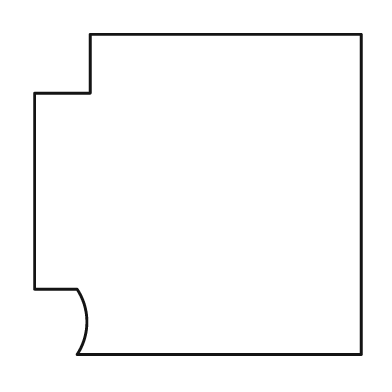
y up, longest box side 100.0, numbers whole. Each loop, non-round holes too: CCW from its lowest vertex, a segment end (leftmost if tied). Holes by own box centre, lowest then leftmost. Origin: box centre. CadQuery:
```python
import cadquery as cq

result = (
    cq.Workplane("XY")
    .moveTo(-37.0, -49.0)
    .lineTo(50.0, -49.0)
    .lineTo(50.0, 49.0)
    .lineTo(-33.0, 49.0)
    .lineTo(-33.0, 31.0)
    .lineTo(-50.0, 31.0)
    .lineTo(-50.0, -29.0)
    .lineTo(-37.0, -29.0)
    .threePointArc((-34.0, -39.0), (-37.0, -49.0))
    .close()
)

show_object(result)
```